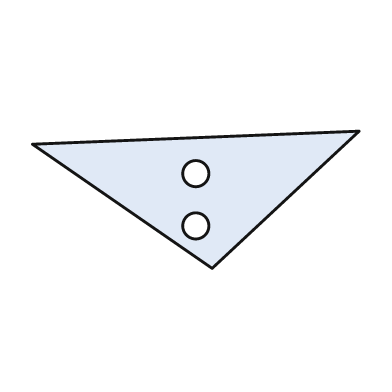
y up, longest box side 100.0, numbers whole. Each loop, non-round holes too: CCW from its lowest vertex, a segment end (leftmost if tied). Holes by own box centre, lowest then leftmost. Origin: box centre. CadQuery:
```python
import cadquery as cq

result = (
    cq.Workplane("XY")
    .moveTo(5.0, -21.0)
    .lineTo(50.0, 21.0)
    .lineTo(-50.0, 17.0)
    .close()
    .moveTo(0.0, -8.0)
    .circle(4.0)
    .moveTo(0.0, 8.0)
    .circle(4.0)
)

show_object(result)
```